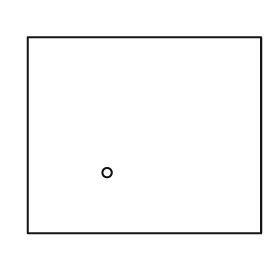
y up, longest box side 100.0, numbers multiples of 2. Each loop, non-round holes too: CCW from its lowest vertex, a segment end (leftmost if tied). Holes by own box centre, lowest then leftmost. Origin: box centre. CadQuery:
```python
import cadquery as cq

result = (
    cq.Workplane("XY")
    .moveTo(-50.0, -42.0)
    .lineTo(50.0, -42.0)
    .lineTo(50.0, 42.0)
    .lineTo(-50.0, 42.0)
    .close()
    .moveTo(-16.0, -16.0)
    .circle(2.0)
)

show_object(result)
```